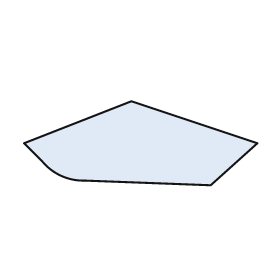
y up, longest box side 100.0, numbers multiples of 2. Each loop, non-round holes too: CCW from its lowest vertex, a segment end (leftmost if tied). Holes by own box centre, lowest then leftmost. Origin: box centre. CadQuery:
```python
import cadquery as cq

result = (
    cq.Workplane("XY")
    .moveTo(30.0, -18.0)
    .lineTo(50.0, 0.0)
    .lineTo(-4.0, 18.0)
    .lineTo(-50.0, 0.0)
    .lineTo(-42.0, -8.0)
    .threePointArc((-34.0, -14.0), (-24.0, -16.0))
    .close()
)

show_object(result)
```